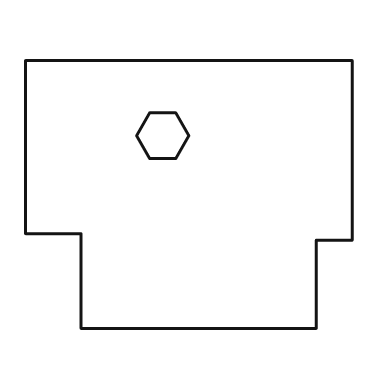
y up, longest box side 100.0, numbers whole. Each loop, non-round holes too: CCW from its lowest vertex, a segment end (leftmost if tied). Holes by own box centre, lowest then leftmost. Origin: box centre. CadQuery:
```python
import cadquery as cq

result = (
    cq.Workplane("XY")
    .moveTo(-33.0, -41.0)
    .lineTo(39.0, -41.0)
    .lineTo(39.0, -14.0)
    .lineTo(50.0, -14.0)
    .lineTo(50.0, 41.0)
    .lineTo(-50.0, 41.0)
    .lineTo(-50.0, -12.0)
    .lineTo(-33.0, -12.0)
    .close()
    .moveTo(-12.0, 11.0)
    .lineTo(-4.0, 11.0)
    .lineTo(0.0, 18.0)
    .lineTo(-4.0, 25.0)
    .lineTo(-12.0, 25.0)
    .lineTo(-16.0, 18.0)
    .close()
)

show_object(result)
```